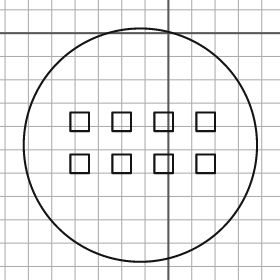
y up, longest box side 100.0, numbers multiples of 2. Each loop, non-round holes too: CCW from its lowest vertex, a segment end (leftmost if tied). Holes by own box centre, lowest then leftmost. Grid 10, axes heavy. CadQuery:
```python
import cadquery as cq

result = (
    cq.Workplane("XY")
    .moveTo(-12.0, -48.0)
    .circle(50.0)
    .moveTo(-42.0, -60.0)
    .lineTo(-34.0, -60.0)
    .lineTo(-34.0, -52.0)
    .lineTo(-42.0, -52.0)
    .close()
    .moveTo(-24.0, -60.0)
    .lineTo(-16.0, -60.0)
    .lineTo(-16.0, -52.0)
    .lineTo(-24.0, -52.0)
    .close()
    .moveTo(-6.0, -60.0)
    .lineTo(2.0, -60.0)
    .lineTo(2.0, -52.0)
    .lineTo(-6.0, -52.0)
    .close()
    .moveTo(12.0, -60.0)
    .lineTo(20.0, -60.0)
    .lineTo(20.0, -52.0)
    .lineTo(12.0, -52.0)
    .close()
    .moveTo(-42.0, -42.0)
    .lineTo(-34.0, -42.0)
    .lineTo(-34.0, -34.0)
    .lineTo(-42.0, -34.0)
    .close()
    .moveTo(-24.0, -42.0)
    .lineTo(-16.0, -42.0)
    .lineTo(-16.0, -34.0)
    .lineTo(-24.0, -34.0)
    .close()
    .moveTo(-6.0, -42.0)
    .lineTo(2.0, -42.0)
    .lineTo(2.0, -34.0)
    .lineTo(-6.0, -34.0)
    .close()
    .moveTo(12.0, -42.0)
    .lineTo(20.0, -42.0)
    .lineTo(20.0, -34.0)
    .lineTo(12.0, -34.0)
    .close()
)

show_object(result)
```